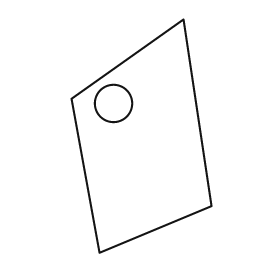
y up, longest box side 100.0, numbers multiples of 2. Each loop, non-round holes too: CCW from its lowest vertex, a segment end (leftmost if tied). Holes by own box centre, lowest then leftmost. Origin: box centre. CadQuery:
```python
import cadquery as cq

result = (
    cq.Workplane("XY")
    .moveTo(-18.0, -50.0)
    .lineTo(30.0, -30.0)
    .lineTo(18.0, 50.0)
    .lineTo(-30.0, 16.0)
    .close()
    .moveTo(-12.0, 14.0)
    .circle(8.0)
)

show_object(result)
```